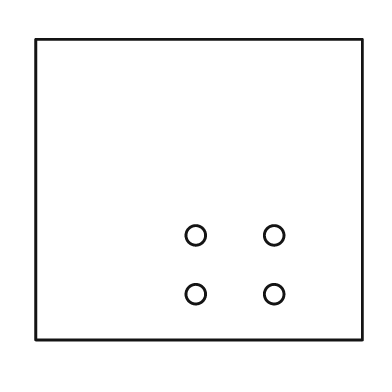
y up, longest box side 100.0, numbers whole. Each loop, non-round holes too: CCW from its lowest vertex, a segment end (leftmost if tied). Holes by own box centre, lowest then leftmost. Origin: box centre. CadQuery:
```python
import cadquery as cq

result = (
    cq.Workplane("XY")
    .moveTo(-50.0, -46.0)
    .lineTo(50.0, -46.0)
    .lineTo(50.0, 46.0)
    .lineTo(-50.0, 46.0)
    .close()
    .moveTo(-1.0, -32.0)
    .circle(3.0)
    .moveTo(23.0, -32.0)
    .circle(3.0)
    .moveTo(-1.0, -14.0)
    .circle(3.0)
    .moveTo(23.0, -14.0)
    .circle(3.0)
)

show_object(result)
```